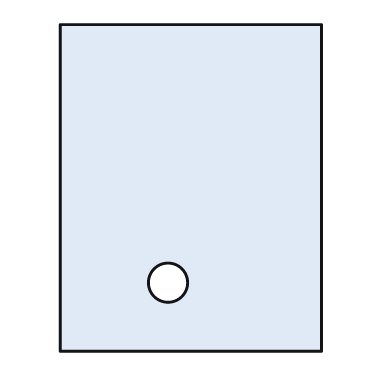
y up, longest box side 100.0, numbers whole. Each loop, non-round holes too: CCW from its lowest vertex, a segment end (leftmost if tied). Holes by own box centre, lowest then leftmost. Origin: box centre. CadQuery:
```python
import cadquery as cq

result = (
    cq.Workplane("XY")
    .moveTo(-40.0, -50.0)
    .lineTo(40.0, -50.0)
    .lineTo(40.0, 50.0)
    .lineTo(-40.0, 50.0)
    .close()
    .moveTo(-7.0, -29.0)
    .circle(6.0)
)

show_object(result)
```